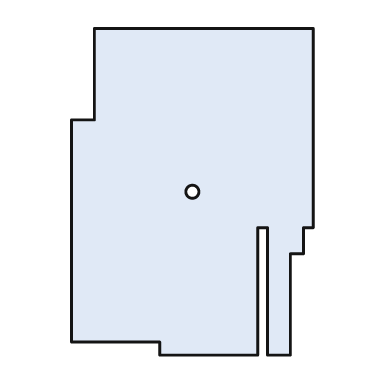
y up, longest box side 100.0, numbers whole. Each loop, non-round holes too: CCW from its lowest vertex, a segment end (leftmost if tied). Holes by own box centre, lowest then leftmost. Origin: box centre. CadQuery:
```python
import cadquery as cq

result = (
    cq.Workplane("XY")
    .moveTo(-10.0, -50.0)
    .lineTo(20.0, -50.0)
    .lineTo(20.0, -11.0)
    .lineTo(23.0, -11.0)
    .lineTo(23.0, -50.0)
    .lineTo(30.0, -50.0)
    .lineTo(30.0, -19.0)
    .lineTo(34.0, -19.0)
    .lineTo(34.0, -11.0)
    .lineTo(37.0, -11.0)
    .lineTo(37.0, 50.0)
    .lineTo(-30.0, 50.0)
    .lineTo(-30.0, 22.0)
    .lineTo(-37.0, 22.0)
    .lineTo(-37.0, -46.0)
    .lineTo(-10.0, -46.0)
    .close()
    .moveTo(0.0, 0.0)
    .circle(2.0)
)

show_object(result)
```